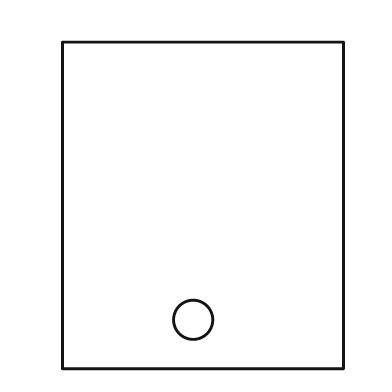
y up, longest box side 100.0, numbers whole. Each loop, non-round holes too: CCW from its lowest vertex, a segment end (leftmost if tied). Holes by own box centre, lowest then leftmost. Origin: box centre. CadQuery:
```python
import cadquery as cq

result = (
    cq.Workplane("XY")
    .moveTo(-43.0, -50.0)
    .lineTo(43.0, -50.0)
    .lineTo(43.0, 50.0)
    .lineTo(-43.0, 50.0)
    .close()
    .moveTo(-3.0, -35.0)
    .circle(6.0)
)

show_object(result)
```